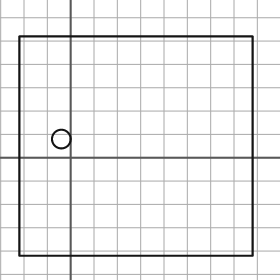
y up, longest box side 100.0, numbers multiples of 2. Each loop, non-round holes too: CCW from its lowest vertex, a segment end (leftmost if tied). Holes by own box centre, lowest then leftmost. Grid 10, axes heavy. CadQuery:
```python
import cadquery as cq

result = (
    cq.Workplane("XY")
    .moveTo(-22.0, -42.0)
    .lineTo(78.0, -42.0)
    .lineTo(78.0, 52.0)
    .lineTo(-22.0, 52.0)
    .close()
    .moveTo(-4.0, 8.0)
    .circle(4.0)
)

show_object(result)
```